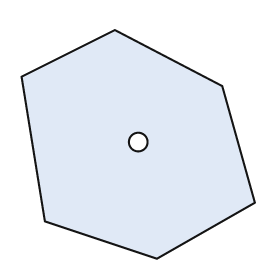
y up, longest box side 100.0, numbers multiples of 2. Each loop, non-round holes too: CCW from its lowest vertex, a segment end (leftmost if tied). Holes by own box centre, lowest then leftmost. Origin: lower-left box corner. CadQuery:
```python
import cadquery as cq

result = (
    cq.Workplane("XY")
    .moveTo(58.0, 0.0)
    .lineTo(100.0, 24.0)
    .lineTo(86.0, 74.0)
    .lineTo(40.0, 98.0)
    .lineTo(0.0, 78.0)
    .lineTo(10.0, 16.0)
    .close()
    .moveTo(50.0, 50.0)
    .circle(4.0)
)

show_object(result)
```